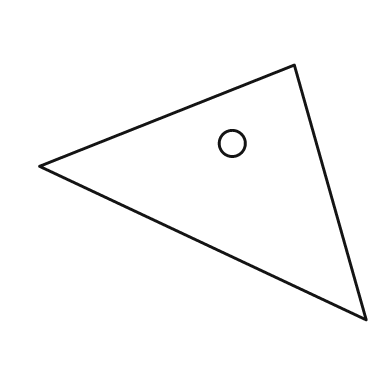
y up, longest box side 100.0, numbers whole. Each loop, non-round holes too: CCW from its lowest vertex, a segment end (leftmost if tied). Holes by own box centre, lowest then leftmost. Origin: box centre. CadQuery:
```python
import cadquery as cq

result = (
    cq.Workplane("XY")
    .moveTo(50.0, -39.0)
    .lineTo(28.0, 39.0)
    .lineTo(-50.0, 8.0)
    .close()
    .moveTo(9.0, 15.0)
    .circle(4.0)
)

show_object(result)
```